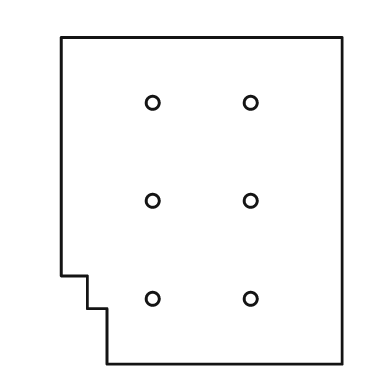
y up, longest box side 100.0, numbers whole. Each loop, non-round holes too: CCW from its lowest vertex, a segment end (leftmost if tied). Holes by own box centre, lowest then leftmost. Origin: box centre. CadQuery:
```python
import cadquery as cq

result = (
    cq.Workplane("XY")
    .moveTo(-29.0, -50.0)
    .lineTo(43.0, -50.0)
    .lineTo(43.0, 50.0)
    .lineTo(-43.0, 50.0)
    .lineTo(-43.0, -23.0)
    .lineTo(-35.0, -23.0)
    .lineTo(-35.0, -33.0)
    .lineTo(-29.0, -33.0)
    .close()
    .moveTo(-15.0, -30.0)
    .circle(2.0)
    .moveTo(15.0, -30.0)
    .circle(2.0)
    .moveTo(-15.0, 0.0)
    .circle(2.0)
    .moveTo(15.0, 0.0)
    .circle(2.0)
    .moveTo(-15.0, 30.0)
    .circle(2.0)
    .moveTo(15.0, 30.0)
    .circle(2.0)
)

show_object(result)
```